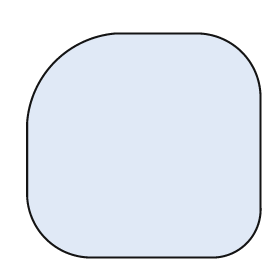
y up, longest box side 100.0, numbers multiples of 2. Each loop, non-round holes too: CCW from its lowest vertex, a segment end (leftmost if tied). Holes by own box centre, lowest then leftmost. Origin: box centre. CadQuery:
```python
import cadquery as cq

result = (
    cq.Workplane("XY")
    .moveTo(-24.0, -48.0)
    .lineTo(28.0, -48.0)
    .threePointArc((44.0, -42.0), (50.0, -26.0))
    .lineTo(50.0, 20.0)
    .threePointArc((42.0, 40.0), (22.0, 48.0))
    .lineTo(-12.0, 48.0)
    .threePointArc((-38.0, 36.0), (-50.0, 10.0))
    .lineTo(-50.0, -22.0)
    .threePointArc((-42.0, -40.0), (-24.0, -48.0))
    .close()
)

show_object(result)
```